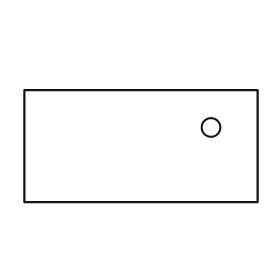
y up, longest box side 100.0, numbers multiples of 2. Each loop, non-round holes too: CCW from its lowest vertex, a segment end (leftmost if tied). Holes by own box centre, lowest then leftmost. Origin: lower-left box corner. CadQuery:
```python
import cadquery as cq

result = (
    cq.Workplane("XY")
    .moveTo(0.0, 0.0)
    .lineTo(100.0, 0.0)
    .lineTo(100.0, 48.0)
    .lineTo(0.0, 48.0)
    .close()
    .moveTo(80.0, 32.0)
    .circle(4.0)
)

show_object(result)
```